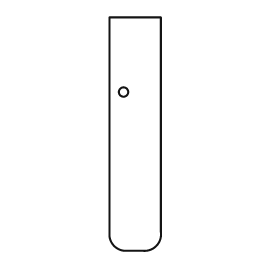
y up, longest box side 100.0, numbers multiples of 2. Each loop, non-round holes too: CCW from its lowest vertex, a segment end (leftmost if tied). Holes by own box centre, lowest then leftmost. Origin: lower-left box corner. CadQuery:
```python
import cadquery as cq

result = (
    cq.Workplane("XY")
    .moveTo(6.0, 0.0)
    .lineTo(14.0, 0.0)
    .threePointArc((20.0, 2.0), (22.0, 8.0))
    .lineTo(22.0, 100.0)
    .lineTo(0.0, 100.0)
    .lineTo(0.0, 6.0)
    .threePointArc((2.0, 2.0), (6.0, 0.0))
    .close()
    .moveTo(6.0, 68.0)
    .circle(2.0)
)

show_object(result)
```